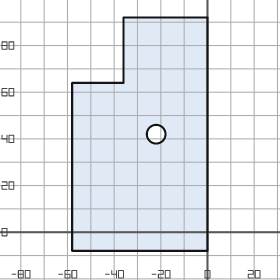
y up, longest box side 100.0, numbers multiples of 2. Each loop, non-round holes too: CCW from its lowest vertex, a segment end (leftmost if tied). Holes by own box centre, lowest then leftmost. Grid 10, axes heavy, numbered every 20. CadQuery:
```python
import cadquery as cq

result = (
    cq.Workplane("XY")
    .moveTo(-58.0, -8.0)
    .lineTo(0.0, -8.0)
    .lineTo(0.0, 92.0)
    .lineTo(-36.0, 92.0)
    .lineTo(-36.0, 64.0)
    .lineTo(-58.0, 64.0)
    .close()
    .moveTo(-22.0, 42.0)
    .circle(4.0)
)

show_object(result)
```